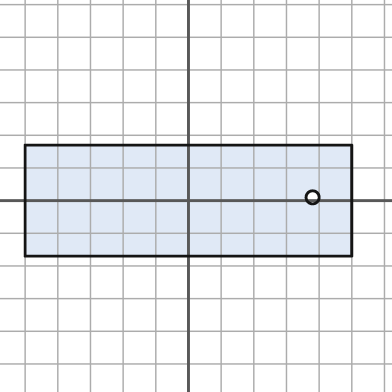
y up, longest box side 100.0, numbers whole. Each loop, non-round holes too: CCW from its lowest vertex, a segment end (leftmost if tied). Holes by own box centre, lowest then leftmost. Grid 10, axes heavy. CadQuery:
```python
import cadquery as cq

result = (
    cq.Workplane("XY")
    .moveTo(-50.0, -17.0)
    .lineTo(50.0, -17.0)
    .lineTo(50.0, 17.0)
    .lineTo(-50.0, 17.0)
    .close()
    .moveTo(38.0, 1.0)
    .circle(2.0)
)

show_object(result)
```